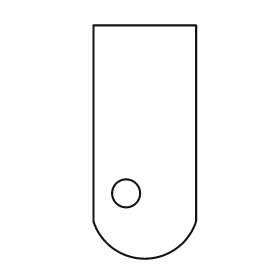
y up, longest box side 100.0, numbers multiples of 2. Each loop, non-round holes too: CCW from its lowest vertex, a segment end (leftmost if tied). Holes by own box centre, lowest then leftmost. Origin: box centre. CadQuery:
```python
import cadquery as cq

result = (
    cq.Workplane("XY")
    .moveTo(-22.0, -34.0)
    .threePointArc((0.0, -50.0), (22.0, -34.0))
    .lineTo(22.0, 50.0)
    .lineTo(-22.0, 50.0)
    .close()
    .moveTo(-8.0, -22.0)
    .circle(6.0)
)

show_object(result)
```